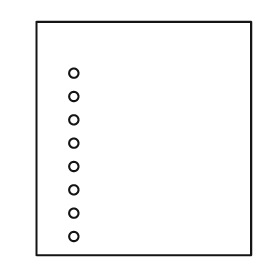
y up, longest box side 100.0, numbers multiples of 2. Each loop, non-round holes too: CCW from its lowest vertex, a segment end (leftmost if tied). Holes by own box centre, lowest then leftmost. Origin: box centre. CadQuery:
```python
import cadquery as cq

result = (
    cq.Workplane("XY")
    .moveTo(-46.0, -50.0)
    .lineTo(46.0, -50.0)
    .lineTo(46.0, 50.0)
    .lineTo(-46.0, 50.0)
    .close()
    .moveTo(-30.0, -42.0)
    .circle(2.0)
    .moveTo(-30.0, -32.0)
    .circle(2.0)
    .moveTo(-30.0, -22.0)
    .circle(2.0)
    .moveTo(-30.0, -12.0)
    .circle(2.0)
    .moveTo(-30.0, -2.0)
    .circle(2.0)
    .moveTo(-30.0, 8.0)
    .circle(2.0)
    .moveTo(-30.0, 18.0)
    .circle(2.0)
    .moveTo(-30.0, 28.0)
    .circle(2.0)
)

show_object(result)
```